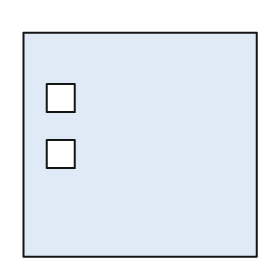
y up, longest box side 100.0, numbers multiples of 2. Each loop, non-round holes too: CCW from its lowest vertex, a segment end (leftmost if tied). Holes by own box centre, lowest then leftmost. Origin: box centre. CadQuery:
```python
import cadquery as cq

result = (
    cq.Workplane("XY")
    .moveTo(-50.0, -48.0)
    .lineTo(50.0, -48.0)
    .lineTo(50.0, 48.0)
    .lineTo(-50.0, 48.0)
    .close()
    .moveTo(-40.0, -10.0)
    .lineTo(-28.0, -10.0)
    .lineTo(-28.0, 2.0)
    .lineTo(-40.0, 2.0)
    .close()
    .moveTo(-40.0, 14.0)
    .lineTo(-28.0, 14.0)
    .lineTo(-28.0, 26.0)
    .lineTo(-40.0, 26.0)
    .close()
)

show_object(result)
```